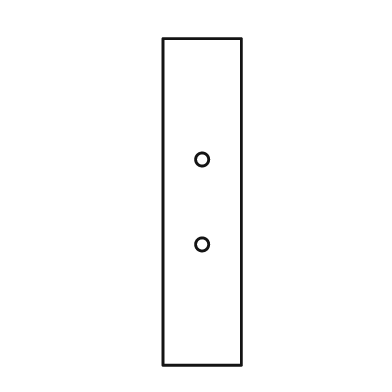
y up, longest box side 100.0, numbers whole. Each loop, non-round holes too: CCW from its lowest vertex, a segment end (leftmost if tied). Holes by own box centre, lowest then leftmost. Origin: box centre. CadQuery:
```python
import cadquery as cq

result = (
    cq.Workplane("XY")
    .moveTo(-12.0, -50.0)
    .lineTo(12.0, -50.0)
    .lineTo(12.0, 50.0)
    .lineTo(-12.0, 50.0)
    .close()
    .moveTo(0.0, -13.0)
    .circle(2.0)
    .moveTo(0.0, 13.0)
    .circle(2.0)
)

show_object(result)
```